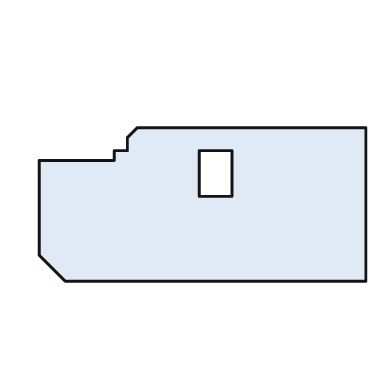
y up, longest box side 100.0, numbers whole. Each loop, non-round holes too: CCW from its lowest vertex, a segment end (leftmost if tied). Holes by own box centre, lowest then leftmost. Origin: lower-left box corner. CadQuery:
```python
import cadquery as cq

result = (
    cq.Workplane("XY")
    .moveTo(8.0, 0.0)
    .lineTo(100.0, 0.0)
    .lineTo(100.0, 47.0)
    .lineTo(30.0, 47.0)
    .lineTo(27.0, 44.0)
    .lineTo(27.0, 40.0)
    .lineTo(23.0, 40.0)
    .lineTo(23.0, 37.0)
    .lineTo(0.0, 37.0)
    .lineTo(0.0, 8.0)
    .close()
    .moveTo(49.0, 26.0)
    .lineTo(59.0, 26.0)
    .lineTo(59.0, 40.0)
    .lineTo(49.0, 40.0)
    .close()
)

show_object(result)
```